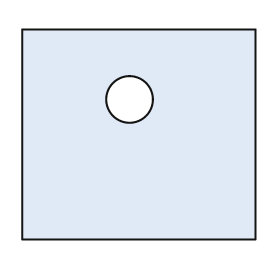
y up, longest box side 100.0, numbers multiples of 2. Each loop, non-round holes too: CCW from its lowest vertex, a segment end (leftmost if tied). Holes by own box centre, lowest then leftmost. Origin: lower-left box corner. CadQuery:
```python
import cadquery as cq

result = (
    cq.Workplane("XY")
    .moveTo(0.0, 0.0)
    .lineTo(100.0, 0.0)
    .lineTo(100.0, 90.0)
    .lineTo(0.0, 90.0)
    .close()
    .moveTo(46.0, 60.0)
    .circle(10.0)
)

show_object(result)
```